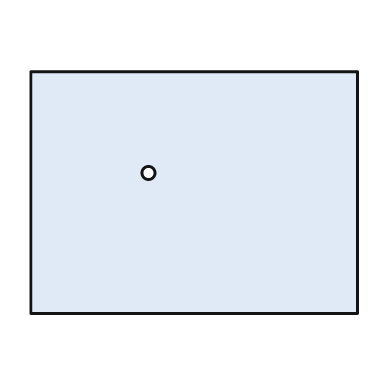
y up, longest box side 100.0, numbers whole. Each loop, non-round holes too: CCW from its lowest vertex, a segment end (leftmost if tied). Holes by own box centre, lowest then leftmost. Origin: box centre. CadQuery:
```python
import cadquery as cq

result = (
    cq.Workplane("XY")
    .moveTo(-50.0, -37.0)
    .lineTo(50.0, -37.0)
    .lineTo(50.0, 37.0)
    .lineTo(-50.0, 37.0)
    .close()
    .moveTo(-14.0, 6.0)
    .circle(2.0)
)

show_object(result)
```